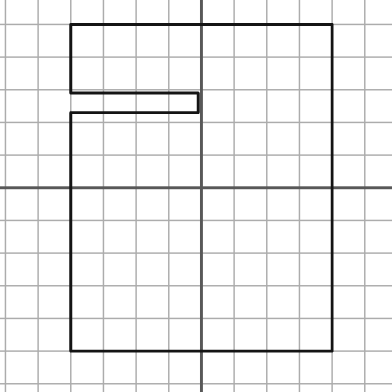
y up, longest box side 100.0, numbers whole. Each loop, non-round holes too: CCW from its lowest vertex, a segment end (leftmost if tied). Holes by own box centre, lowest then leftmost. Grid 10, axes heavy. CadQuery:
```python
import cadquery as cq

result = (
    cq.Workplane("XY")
    .moveTo(-40.0, -50.0)
    .lineTo(40.0, -50.0)
    .lineTo(40.0, 50.0)
    .lineTo(-40.0, 50.0)
    .lineTo(-40.0, 29.0)
    .lineTo(-1.0, 29.0)
    .lineTo(-1.0, 23.0)
    .lineTo(-40.0, 23.0)
    .close()
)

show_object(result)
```